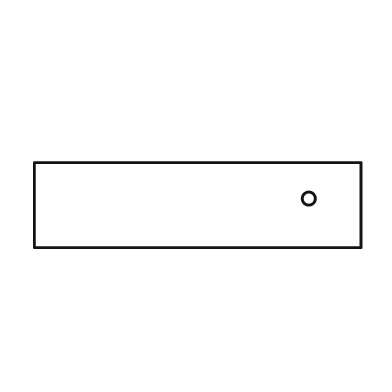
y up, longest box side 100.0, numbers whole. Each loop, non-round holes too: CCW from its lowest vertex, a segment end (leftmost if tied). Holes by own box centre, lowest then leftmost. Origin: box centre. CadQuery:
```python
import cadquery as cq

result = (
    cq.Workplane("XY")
    .moveTo(-50.0, -13.0)
    .lineTo(50.0, -13.0)
    .lineTo(50.0, 13.0)
    .lineTo(-50.0, 13.0)
    .close()
    .moveTo(34.0, 2.0)
    .circle(2.0)
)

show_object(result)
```